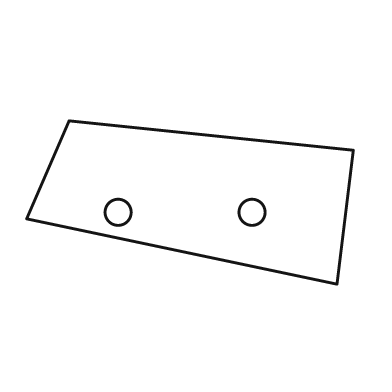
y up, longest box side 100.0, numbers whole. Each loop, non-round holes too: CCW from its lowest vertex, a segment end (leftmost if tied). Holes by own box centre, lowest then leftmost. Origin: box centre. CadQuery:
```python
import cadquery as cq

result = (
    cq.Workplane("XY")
    .moveTo(45.0, -25.0)
    .lineTo(50.0, 16.0)
    .lineTo(-37.0, 25.0)
    .lineTo(-50.0, -5.0)
    .close()
    .moveTo(-22.0, -3.0)
    .circle(4.0)
    .moveTo(19.0, -3.0)
    .circle(4.0)
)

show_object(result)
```